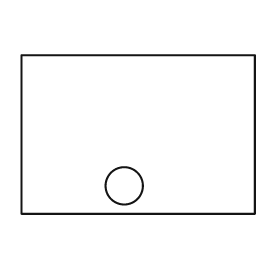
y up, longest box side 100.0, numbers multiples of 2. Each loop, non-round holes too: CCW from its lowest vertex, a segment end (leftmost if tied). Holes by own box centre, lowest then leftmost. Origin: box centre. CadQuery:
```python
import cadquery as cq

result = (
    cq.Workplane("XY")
    .moveTo(-50.0, -34.0)
    .lineTo(50.0, -34.0)
    .lineTo(50.0, 34.0)
    .lineTo(-50.0, 34.0)
    .close()
    .moveTo(-6.0, -22.0)
    .circle(8.0)
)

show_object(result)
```